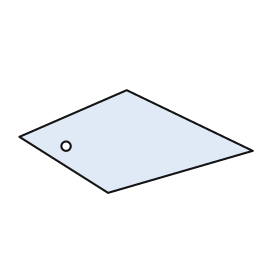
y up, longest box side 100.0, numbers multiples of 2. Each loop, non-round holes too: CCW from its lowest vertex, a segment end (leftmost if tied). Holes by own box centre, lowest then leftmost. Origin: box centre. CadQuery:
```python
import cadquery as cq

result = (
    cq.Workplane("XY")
    .moveTo(-12.0, -22.0)
    .lineTo(50.0, -4.0)
    .lineTo(-4.0, 22.0)
    .lineTo(-50.0, 2.0)
    .close()
    .moveTo(-30.0, -2.0)
    .circle(2.0)
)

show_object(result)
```